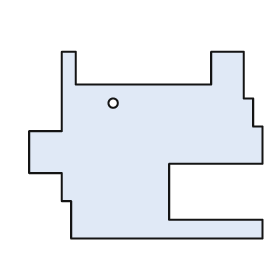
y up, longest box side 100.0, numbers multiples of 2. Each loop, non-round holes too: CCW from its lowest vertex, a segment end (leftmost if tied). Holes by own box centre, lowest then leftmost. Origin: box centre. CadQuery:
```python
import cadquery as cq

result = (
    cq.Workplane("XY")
    .moveTo(-32.0, -40.0)
    .lineTo(50.0, -40.0)
    .lineTo(50.0, -32.0)
    .lineTo(10.0, -32.0)
    .lineTo(10.0, -8.0)
    .lineTo(50.0, -8.0)
    .lineTo(50.0, 8.0)
    .lineTo(46.0, 8.0)
    .lineTo(46.0, 20.0)
    .lineTo(42.0, 20.0)
    .lineTo(42.0, 40.0)
    .lineTo(28.0, 40.0)
    .lineTo(28.0, 26.0)
    .lineTo(-30.0, 26.0)
    .lineTo(-30.0, 40.0)
    .lineTo(-36.0, 40.0)
    .lineTo(-36.0, 6.0)
    .lineTo(-50.0, 6.0)
    .lineTo(-50.0, -12.0)
    .lineTo(-36.0, -12.0)
    .lineTo(-36.0, -24.0)
    .lineTo(-32.0, -24.0)
    .close()
    .moveTo(-14.0, 18.0)
    .circle(2.0)
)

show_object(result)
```